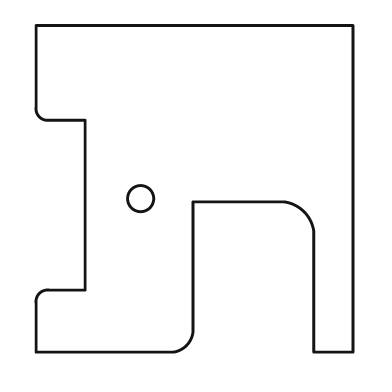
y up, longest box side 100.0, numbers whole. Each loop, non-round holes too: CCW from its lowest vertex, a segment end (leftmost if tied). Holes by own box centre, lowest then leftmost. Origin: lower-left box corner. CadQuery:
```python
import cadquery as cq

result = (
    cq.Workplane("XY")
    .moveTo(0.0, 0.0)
    .lineTo(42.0, 0.0)
    .threePointArc((46.0, 2.0), (48.0, 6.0))
    .lineTo(48.0, 46.0)
    .lineTo(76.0, 46.0)
    .threePointArc((82.0, 43.0), (85.0, 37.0))
    .lineTo(85.0, 0.0)
    .lineTo(97.0, 0.0)
    .lineTo(97.0, 100.0)
    .lineTo(0.0, 100.0)
    .lineTo(0.0, 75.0)
    .threePointArc((1.0, 72.0), (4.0, 71.0))
    .lineTo(15.0, 71.0)
    .lineTo(15.0, 19.0)
    .lineTo(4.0, 19.0)
    .threePointArc((1.0, 18.0), (0.0, 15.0))
    .close()
    .moveTo(32.0, 47.0)
    .circle(4.0)
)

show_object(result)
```